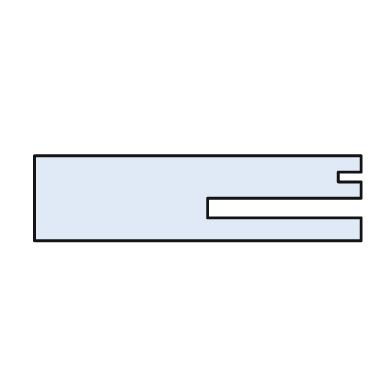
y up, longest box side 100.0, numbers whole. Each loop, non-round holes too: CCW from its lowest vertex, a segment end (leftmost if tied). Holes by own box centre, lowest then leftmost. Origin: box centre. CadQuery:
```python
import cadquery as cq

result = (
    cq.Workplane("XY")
    .moveTo(-50.0, -13.0)
    .lineTo(50.0, -13.0)
    .lineTo(50.0, -6.0)
    .lineTo(3.0, -6.0)
    .lineTo(3.0, 0.0)
    .lineTo(50.0, 0.0)
    .lineTo(50.0, 5.0)
    .lineTo(43.0, 5.0)
    .lineTo(43.0, 8.0)
    .lineTo(50.0, 8.0)
    .lineTo(50.0, 13.0)
    .lineTo(-50.0, 13.0)
    .close()
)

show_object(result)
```